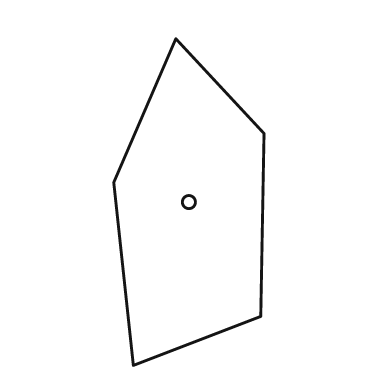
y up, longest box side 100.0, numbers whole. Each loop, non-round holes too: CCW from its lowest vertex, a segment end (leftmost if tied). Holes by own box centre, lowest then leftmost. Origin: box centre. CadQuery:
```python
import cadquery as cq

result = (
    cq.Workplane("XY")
    .moveTo(-17.0, -50.0)
    .lineTo(22.0, -35.0)
    .lineTo(23.0, 21.0)
    .lineTo(-4.0, 50.0)
    .lineTo(-23.0, 6.0)
    .close()
    .moveTo(0.0, 0.0)
    .circle(2.0)
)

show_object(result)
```